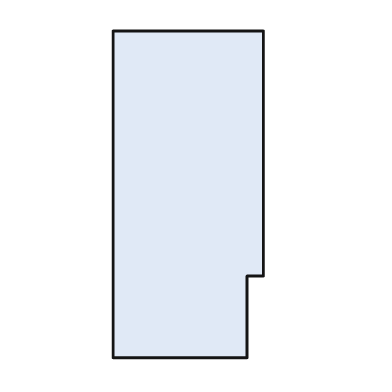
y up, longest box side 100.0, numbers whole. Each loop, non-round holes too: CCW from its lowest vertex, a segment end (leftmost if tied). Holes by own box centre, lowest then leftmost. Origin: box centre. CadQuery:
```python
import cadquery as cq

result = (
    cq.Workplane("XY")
    .moveTo(-23.0, -50.0)
    .lineTo(18.0, -50.0)
    .lineTo(18.0, -25.0)
    .lineTo(23.0, -25.0)
    .lineTo(23.0, 50.0)
    .lineTo(-23.0, 50.0)
    .close()
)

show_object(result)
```